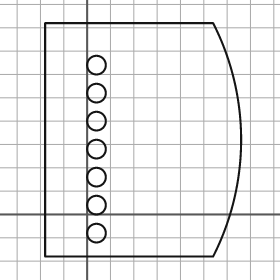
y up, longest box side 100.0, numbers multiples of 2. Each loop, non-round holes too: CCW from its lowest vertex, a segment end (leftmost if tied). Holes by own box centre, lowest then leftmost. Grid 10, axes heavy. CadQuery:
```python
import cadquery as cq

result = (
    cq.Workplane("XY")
    .moveTo(-18.0, -18.0)
    .lineTo(54.0, -18.0)
    .threePointArc((66.0, 32.0), (54.0, 82.0))
    .lineTo(-18.0, 82.0)
    .close()
    .moveTo(4.0, -8.0)
    .circle(4.0)
    .moveTo(4.0, 4.0)
    .circle(4.0)
    .moveTo(4.0, 16.0)
    .circle(4.0)
    .moveTo(4.0, 28.0)
    .circle(4.0)
    .moveTo(4.0, 40.0)
    .circle(4.0)
    .moveTo(4.0, 52.0)
    .circle(4.0)
    .moveTo(4.0, 64.0)
    .circle(4.0)
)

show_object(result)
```